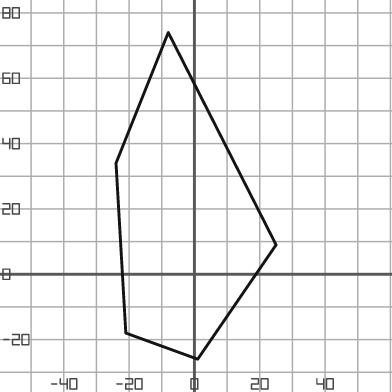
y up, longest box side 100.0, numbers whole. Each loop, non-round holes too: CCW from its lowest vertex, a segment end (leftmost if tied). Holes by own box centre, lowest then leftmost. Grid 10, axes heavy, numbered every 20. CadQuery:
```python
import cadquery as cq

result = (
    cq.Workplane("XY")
    .moveTo(1.0, -26.0)
    .lineTo(25.0, 9.0)
    .lineTo(-8.0, 74.0)
    .lineTo(-24.0, 34.0)
    .lineTo(-21.0, -18.0)
    .close()
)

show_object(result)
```